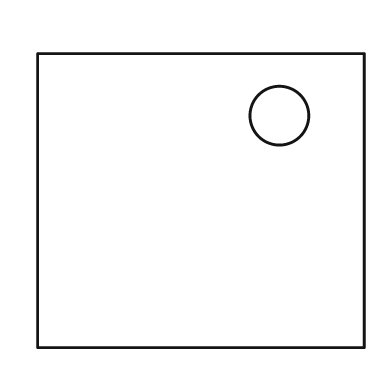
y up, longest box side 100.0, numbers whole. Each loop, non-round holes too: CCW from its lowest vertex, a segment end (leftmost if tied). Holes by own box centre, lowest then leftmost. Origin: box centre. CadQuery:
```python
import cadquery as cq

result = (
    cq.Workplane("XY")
    .moveTo(-50.0, -45.0)
    .lineTo(50.0, -45.0)
    .lineTo(50.0, 45.0)
    .lineTo(-50.0, 45.0)
    .close()
    .moveTo(24.0, 26.0)
    .circle(9.0)
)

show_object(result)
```